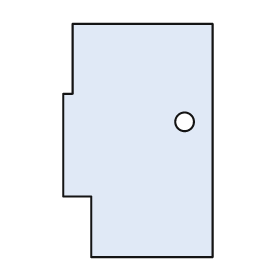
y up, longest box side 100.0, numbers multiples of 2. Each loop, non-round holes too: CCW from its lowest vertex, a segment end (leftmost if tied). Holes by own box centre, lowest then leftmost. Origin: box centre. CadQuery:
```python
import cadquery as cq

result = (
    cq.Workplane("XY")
    .moveTo(-20.0, -50.0)
    .lineTo(32.0, -50.0)
    .lineTo(32.0, 50.0)
    .lineTo(-28.0, 50.0)
    .lineTo(-28.0, 20.0)
    .lineTo(-32.0, 20.0)
    .lineTo(-32.0, -24.0)
    .lineTo(-20.0, -24.0)
    .close()
    .moveTo(20.0, 8.0)
    .circle(4.0)
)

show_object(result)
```